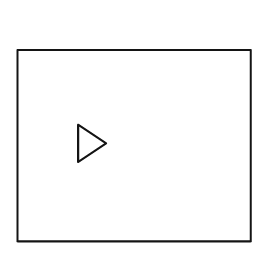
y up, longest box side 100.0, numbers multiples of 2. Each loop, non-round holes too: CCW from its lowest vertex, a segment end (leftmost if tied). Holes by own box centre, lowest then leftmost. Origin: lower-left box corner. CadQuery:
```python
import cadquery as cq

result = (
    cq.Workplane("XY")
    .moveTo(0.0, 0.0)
    .lineTo(100.0, 0.0)
    .lineTo(100.0, 82.0)
    .lineTo(0.0, 82.0)
    .close()
    .moveTo(26.0, 34.0)
    .lineTo(38.0, 42.0)
    .lineTo(26.0, 50.0)
    .close()
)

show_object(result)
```